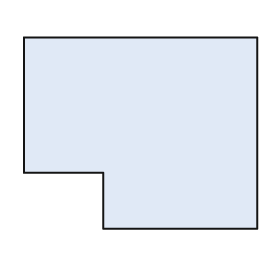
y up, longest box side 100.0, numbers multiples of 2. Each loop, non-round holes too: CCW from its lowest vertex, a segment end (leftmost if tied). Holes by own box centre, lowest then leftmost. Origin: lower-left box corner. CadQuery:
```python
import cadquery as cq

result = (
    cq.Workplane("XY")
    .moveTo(34.0, 0.0)
    .lineTo(100.0, 0.0)
    .lineTo(100.0, 82.0)
    .lineTo(0.0, 82.0)
    .lineTo(0.0, 24.0)
    .lineTo(34.0, 24.0)
    .close()
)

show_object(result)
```